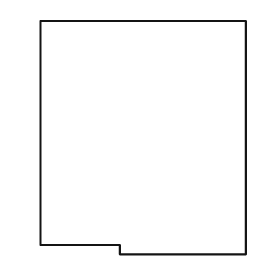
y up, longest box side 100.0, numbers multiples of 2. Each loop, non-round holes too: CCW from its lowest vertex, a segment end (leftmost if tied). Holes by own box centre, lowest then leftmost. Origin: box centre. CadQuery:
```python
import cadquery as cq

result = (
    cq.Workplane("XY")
    .moveTo(-10.0, -50.0)
    .lineTo(44.0, -50.0)
    .lineTo(44.0, 50.0)
    .lineTo(-44.0, 50.0)
    .lineTo(-44.0, -46.0)
    .lineTo(-10.0, -46.0)
    .close()
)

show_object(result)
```